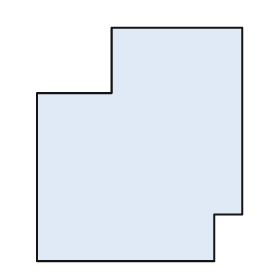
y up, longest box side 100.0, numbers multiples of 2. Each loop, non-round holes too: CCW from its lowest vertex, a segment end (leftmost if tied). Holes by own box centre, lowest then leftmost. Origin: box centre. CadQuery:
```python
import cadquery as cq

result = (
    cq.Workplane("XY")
    .moveTo(-44.0, -50.0)
    .lineTo(32.0, -50.0)
    .lineTo(32.0, -30.0)
    .lineTo(44.0, -30.0)
    .lineTo(44.0, 50.0)
    .lineTo(-12.0, 50.0)
    .lineTo(-12.0, 22.0)
    .lineTo(-44.0, 22.0)
    .close()
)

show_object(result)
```